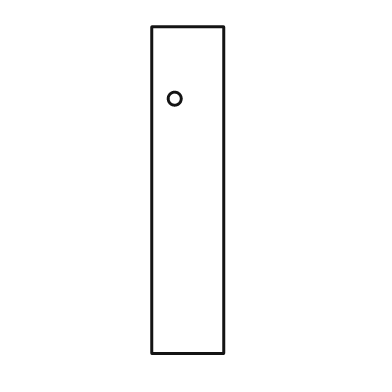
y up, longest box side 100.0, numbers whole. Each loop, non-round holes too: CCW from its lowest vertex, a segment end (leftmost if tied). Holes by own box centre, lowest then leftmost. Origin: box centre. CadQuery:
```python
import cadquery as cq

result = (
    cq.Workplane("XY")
    .moveTo(-11.0, -50.0)
    .lineTo(11.0, -50.0)
    .lineTo(11.0, 50.0)
    .lineTo(-11.0, 50.0)
    .close()
    .moveTo(-4.0, 28.0)
    .circle(2.0)
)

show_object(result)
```